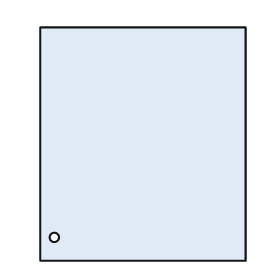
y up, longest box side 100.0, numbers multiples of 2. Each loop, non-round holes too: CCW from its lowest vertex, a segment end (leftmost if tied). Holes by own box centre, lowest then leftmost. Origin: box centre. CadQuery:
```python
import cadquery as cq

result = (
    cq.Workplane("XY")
    .moveTo(-44.0, -50.0)
    .lineTo(44.0, -50.0)
    .lineTo(44.0, 50.0)
    .lineTo(-44.0, 50.0)
    .close()
    .moveTo(-38.0, -40.0)
    .circle(2.0)
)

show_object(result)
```